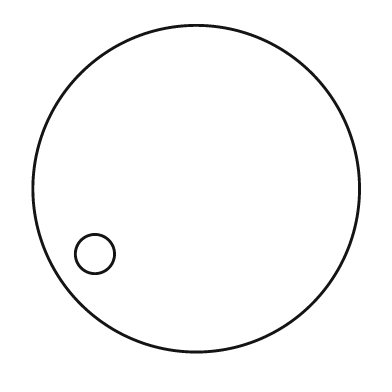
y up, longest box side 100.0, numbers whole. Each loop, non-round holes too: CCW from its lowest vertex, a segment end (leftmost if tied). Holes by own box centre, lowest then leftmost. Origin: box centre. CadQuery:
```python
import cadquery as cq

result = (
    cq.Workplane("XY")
    .moveTo(0.0, 0.0)
    .circle(50.0)
    .moveTo(-31.0, -20.0)
    .circle(6.0)
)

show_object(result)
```